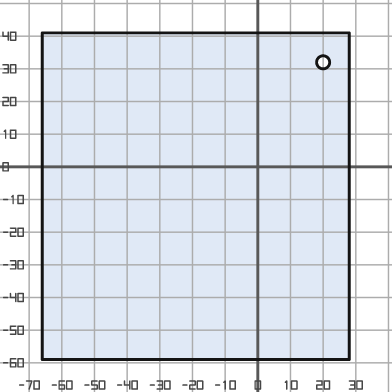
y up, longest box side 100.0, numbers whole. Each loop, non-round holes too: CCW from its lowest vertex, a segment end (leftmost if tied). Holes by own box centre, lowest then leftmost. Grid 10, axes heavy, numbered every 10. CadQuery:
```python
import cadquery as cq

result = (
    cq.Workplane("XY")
    .moveTo(-66.0, -59.0)
    .lineTo(28.0, -59.0)
    .lineTo(28.0, 41.0)
    .lineTo(-66.0, 41.0)
    .close()
    .moveTo(20.0, 32.0)
    .circle(2.0)
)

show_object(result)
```